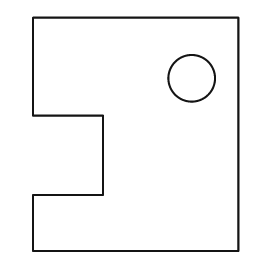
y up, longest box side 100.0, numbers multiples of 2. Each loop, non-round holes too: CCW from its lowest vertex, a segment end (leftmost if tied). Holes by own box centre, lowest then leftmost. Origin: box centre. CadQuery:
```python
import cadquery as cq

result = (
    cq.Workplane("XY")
    .moveTo(-44.0, -50.0)
    .lineTo(44.0, -50.0)
    .lineTo(44.0, 50.0)
    .lineTo(-44.0, 50.0)
    .lineTo(-44.0, 8.0)
    .lineTo(-14.0, 8.0)
    .lineTo(-14.0, -26.0)
    .lineTo(-44.0, -26.0)
    .close()
    .moveTo(24.0, 24.0)
    .circle(10.0)
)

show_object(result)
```